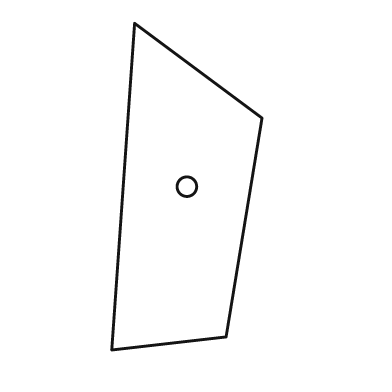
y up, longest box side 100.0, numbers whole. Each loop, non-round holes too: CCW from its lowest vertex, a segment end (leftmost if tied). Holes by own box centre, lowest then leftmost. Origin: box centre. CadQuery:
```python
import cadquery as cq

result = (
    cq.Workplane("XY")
    .moveTo(-23.0, -50.0)
    .lineTo(12.0, -46.0)
    .lineTo(23.0, 21.0)
    .lineTo(-16.0, 50.0)
    .close()
    .moveTo(0.0, 0.0)
    .circle(3.0)
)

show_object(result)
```